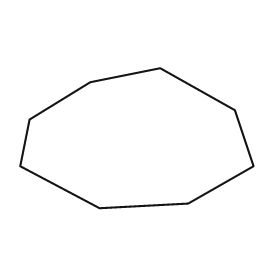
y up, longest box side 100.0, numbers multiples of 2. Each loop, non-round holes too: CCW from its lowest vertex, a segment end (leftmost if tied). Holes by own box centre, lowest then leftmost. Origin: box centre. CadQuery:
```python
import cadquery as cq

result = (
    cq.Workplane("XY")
    .moveTo(-16.0, -30.0)
    .lineTo(22.0, -28.0)
    .lineTo(50.0, -12.0)
    .lineTo(42.0, 12.0)
    .lineTo(10.0, 30.0)
    .lineTo(-20.0, 24.0)
    .lineTo(-46.0, 8.0)
    .lineTo(-50.0, -12.0)
    .close()
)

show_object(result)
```